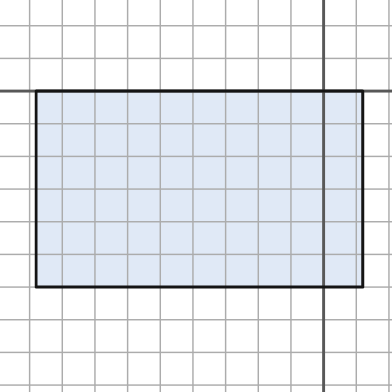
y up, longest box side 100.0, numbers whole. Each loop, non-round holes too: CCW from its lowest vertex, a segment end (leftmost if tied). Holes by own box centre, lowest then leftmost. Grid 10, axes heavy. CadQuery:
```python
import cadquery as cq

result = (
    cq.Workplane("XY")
    .moveTo(-88.0, -60.0)
    .lineTo(12.0, -60.0)
    .lineTo(12.0, 0.0)
    .lineTo(-88.0, 0.0)
    .close()
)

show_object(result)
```